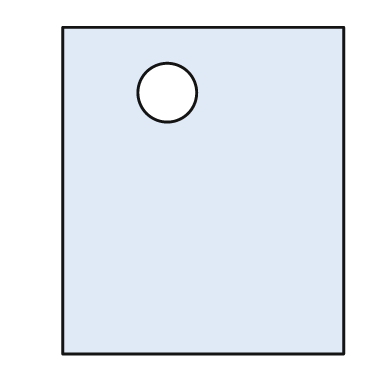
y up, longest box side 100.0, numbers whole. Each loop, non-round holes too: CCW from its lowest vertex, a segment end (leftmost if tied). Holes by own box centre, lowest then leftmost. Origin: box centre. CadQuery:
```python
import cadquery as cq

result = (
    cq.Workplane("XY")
    .moveTo(-43.0, -50.0)
    .lineTo(43.0, -50.0)
    .lineTo(43.0, 50.0)
    .lineTo(-43.0, 50.0)
    .close()
    .moveTo(-11.0, 30.0)
    .circle(9.0)
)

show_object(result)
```